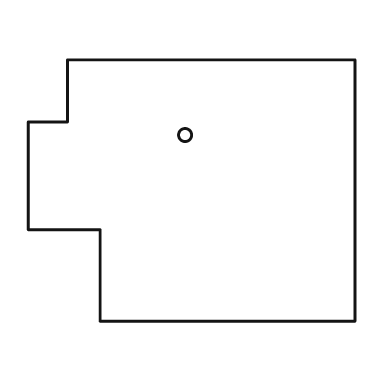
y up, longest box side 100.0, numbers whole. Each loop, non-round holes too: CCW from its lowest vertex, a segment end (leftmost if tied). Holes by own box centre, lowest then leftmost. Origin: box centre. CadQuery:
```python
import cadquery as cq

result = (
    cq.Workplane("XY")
    .moveTo(-28.0, -40.0)
    .lineTo(50.0, -40.0)
    .lineTo(50.0, 40.0)
    .lineTo(-38.0, 40.0)
    .lineTo(-38.0, 21.0)
    .lineTo(-50.0, 21.0)
    .lineTo(-50.0, -12.0)
    .lineTo(-28.0, -12.0)
    .close()
    .moveTo(-2.0, 17.0)
    .circle(2.0)
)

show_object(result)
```